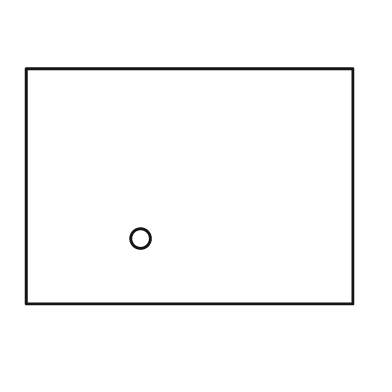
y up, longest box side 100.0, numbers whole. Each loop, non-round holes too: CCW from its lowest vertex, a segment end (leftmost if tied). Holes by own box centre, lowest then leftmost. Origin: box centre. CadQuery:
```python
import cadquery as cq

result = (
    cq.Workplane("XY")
    .moveTo(-50.0, -36.0)
    .lineTo(50.0, -36.0)
    .lineTo(50.0, 36.0)
    .lineTo(-50.0, 36.0)
    .close()
    .moveTo(-15.0, -16.0)
    .circle(3.0)
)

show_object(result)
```